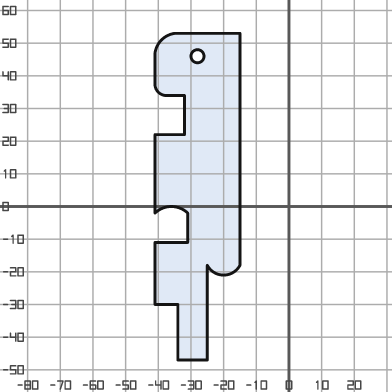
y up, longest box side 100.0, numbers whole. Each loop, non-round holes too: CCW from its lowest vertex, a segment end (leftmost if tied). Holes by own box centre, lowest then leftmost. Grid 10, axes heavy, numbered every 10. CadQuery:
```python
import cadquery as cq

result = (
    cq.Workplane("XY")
    .moveTo(-34.0, -47.0)
    .lineTo(-25.0, -47.0)
    .lineTo(-25.0, -18.0)
    .threePointArc((-20.0, -21.0), (-15.0, -18.0))
    .lineTo(-15.0, 53.0)
    .lineTo(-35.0, 53.0)
    .threePointArc((-39.0, 51.0), (-41.0, 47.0))
    .lineTo(-41.0, 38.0)
    .threePointArc((-40.0, 35.0), (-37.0, 34.0))
    .lineTo(-32.0, 34.0)
    .lineTo(-32.0, 22.0)
    .lineTo(-41.0, 22.0)
    .lineTo(-41.0, -2.0)
    .threePointArc((-36.0, 0.0), (-31.0, -2.0))
    .lineTo(-31.0, -11.0)
    .lineTo(-41.0, -11.0)
    .lineTo(-41.0, -30.0)
    .lineTo(-34.0, -30.0)
    .close()
    .moveTo(-28.0, 46.0)
    .circle(2.0)
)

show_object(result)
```